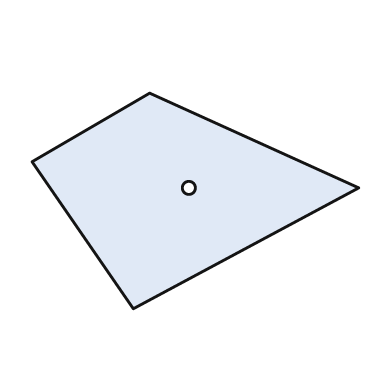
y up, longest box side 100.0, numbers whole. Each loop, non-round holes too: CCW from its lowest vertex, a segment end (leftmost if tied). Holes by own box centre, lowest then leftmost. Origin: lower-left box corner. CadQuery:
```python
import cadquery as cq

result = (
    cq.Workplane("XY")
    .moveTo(31.0, 0.0)
    .lineTo(100.0, 37.0)
    .lineTo(36.0, 66.0)
    .lineTo(0.0, 45.0)
    .close()
    .moveTo(48.0, 37.0)
    .circle(2.0)
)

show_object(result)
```